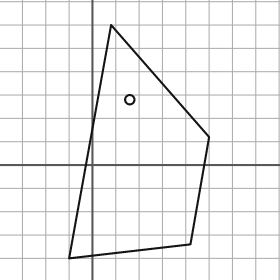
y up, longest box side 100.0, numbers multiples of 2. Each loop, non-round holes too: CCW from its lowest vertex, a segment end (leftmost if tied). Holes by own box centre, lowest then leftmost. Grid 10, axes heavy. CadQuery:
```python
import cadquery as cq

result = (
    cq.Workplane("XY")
    .moveTo(-10.0, -40.0)
    .lineTo(42.0, -34.0)
    .lineTo(50.0, 12.0)
    .lineTo(8.0, 60.0)
    .close()
    .moveTo(16.0, 28.0)
    .circle(2.0)
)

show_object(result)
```